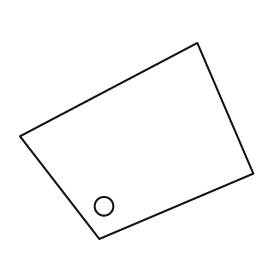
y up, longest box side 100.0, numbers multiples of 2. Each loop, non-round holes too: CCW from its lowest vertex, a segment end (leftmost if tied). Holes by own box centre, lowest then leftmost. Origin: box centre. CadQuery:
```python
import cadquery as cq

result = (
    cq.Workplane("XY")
    .moveTo(-16.0, -42.0)
    .lineTo(50.0, -14.0)
    .lineTo(26.0, 42.0)
    .lineTo(-50.0, 2.0)
    .close()
    .moveTo(-14.0, -28.0)
    .circle(4.0)
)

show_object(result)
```